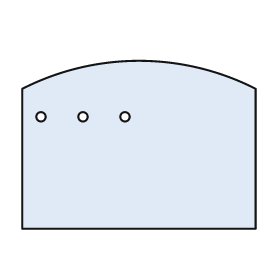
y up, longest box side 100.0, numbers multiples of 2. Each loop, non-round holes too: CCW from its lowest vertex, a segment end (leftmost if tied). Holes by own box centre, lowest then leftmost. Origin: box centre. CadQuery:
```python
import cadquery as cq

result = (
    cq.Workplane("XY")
    .moveTo(-50.0, -36.0)
    .lineTo(50.0, -36.0)
    .lineTo(50.0, 24.0)
    .threePointArc((0.0, 36.0), (-50.0, 24.0))
    .close()
    .moveTo(-42.0, 12.0)
    .circle(2.0)
    .moveTo(-24.0, 12.0)
    .circle(2.0)
    .moveTo(-6.0, 12.0)
    .circle(2.0)
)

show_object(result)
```